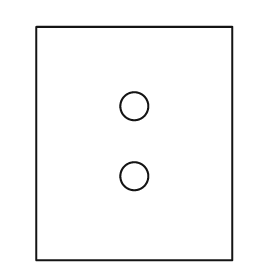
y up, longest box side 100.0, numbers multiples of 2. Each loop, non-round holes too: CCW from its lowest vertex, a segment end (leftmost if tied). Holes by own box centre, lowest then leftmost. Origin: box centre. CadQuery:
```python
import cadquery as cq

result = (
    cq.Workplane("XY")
    .moveTo(-42.0, -50.0)
    .lineTo(42.0, -50.0)
    .lineTo(42.0, 50.0)
    .lineTo(-42.0, 50.0)
    .close()
    .moveTo(0.0, -14.0)
    .circle(6.0)
    .moveTo(0.0, 16.0)
    .circle(6.0)
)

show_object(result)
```